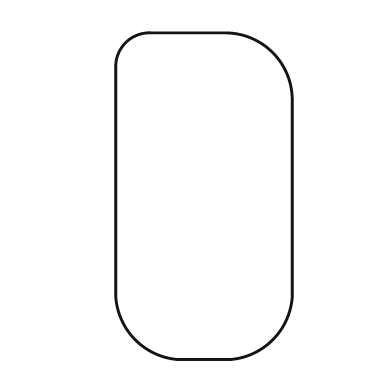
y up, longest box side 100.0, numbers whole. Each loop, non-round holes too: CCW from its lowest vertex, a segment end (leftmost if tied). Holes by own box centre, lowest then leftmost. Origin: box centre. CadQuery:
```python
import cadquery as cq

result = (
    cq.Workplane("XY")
    .moveTo(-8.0, -50.0)
    .lineTo(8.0, -50.0)
    .threePointArc((21.0, -44.0), (27.0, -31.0))
    .lineTo(27.0, 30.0)
    .threePointArc((21.0, 44.0), (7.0, 50.0))
    .lineTo(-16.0, 50.0)
    .threePointArc((-24.0, 47.0), (-27.0, 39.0))
    .lineTo(-27.0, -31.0)
    .threePointArc((-21.0, -44.0), (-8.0, -50.0))
    .close()
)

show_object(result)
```